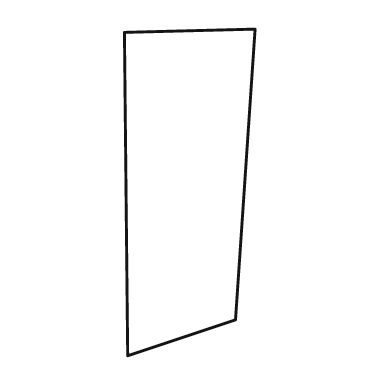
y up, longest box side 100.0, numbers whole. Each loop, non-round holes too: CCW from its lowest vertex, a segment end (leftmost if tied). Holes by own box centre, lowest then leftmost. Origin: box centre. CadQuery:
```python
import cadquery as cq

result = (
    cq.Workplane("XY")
    .moveTo(-19.0, -50.0)
    .lineTo(14.0, -39.0)
    .lineTo(20.0, 50.0)
    .lineTo(-20.0, 49.0)
    .close()
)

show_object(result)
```